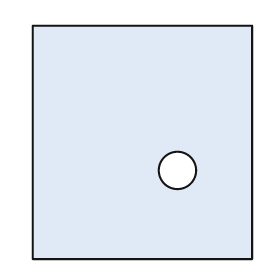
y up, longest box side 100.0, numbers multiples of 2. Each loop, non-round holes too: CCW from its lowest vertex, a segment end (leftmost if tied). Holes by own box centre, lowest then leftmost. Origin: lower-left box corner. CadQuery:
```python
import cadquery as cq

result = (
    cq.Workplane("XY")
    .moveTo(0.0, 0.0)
    .lineTo(94.0, 0.0)
    .lineTo(94.0, 100.0)
    .lineTo(0.0, 100.0)
    .close()
    .moveTo(62.0, 38.0)
    .circle(8.0)
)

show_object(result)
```